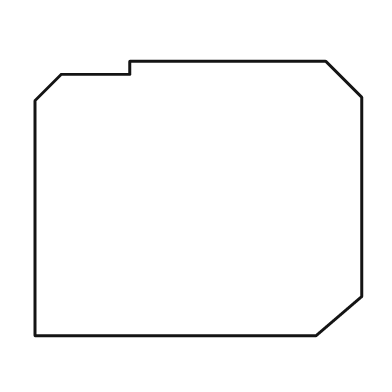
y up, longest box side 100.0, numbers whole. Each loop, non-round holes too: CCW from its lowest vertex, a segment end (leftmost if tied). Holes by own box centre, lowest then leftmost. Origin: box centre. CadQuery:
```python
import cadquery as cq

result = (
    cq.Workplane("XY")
    .moveTo(-50.0, -42.0)
    .lineTo(36.0, -42.0)
    .lineTo(50.0, -30.0)
    .lineTo(50.0, 31.0)
    .lineTo(39.0, 42.0)
    .lineTo(-21.0, 42.0)
    .lineTo(-21.0, 38.0)
    .lineTo(-42.0, 38.0)
    .lineTo(-50.0, 30.0)
    .close()
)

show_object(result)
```